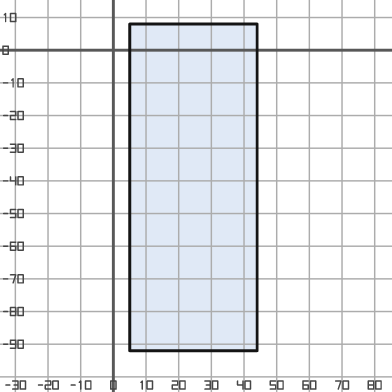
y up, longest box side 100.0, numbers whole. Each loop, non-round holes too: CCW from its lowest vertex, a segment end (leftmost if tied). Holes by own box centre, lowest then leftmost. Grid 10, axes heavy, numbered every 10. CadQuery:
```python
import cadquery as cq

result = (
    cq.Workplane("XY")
    .moveTo(5.0, -92.0)
    .lineTo(44.0, -92.0)
    .lineTo(44.0, 8.0)
    .lineTo(5.0, 8.0)
    .close()
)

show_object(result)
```